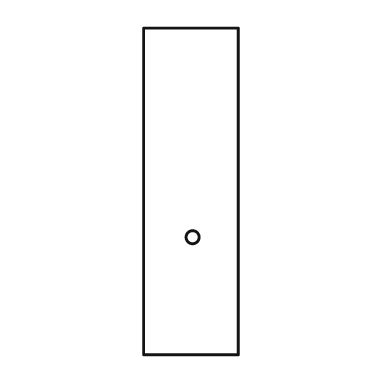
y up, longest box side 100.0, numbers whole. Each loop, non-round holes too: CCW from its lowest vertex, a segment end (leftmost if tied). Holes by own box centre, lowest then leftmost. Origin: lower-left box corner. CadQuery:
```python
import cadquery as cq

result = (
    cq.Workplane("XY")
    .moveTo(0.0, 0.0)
    .lineTo(29.0, 0.0)
    .lineTo(29.0, 100.0)
    .lineTo(0.0, 100.0)
    .close()
    .moveTo(15.0, 36.0)
    .circle(2.0)
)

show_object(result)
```